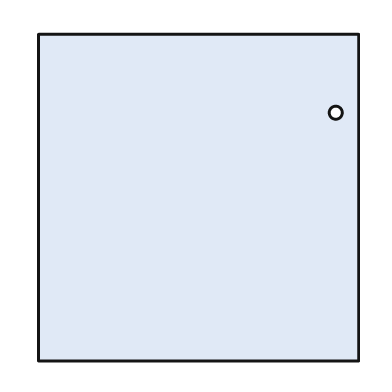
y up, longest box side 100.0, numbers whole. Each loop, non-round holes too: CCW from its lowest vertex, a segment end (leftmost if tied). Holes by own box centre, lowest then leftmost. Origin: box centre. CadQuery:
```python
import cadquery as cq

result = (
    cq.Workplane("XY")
    .moveTo(-49.0, -50.0)
    .lineTo(49.0, -50.0)
    .lineTo(49.0, 50.0)
    .lineTo(-49.0, 50.0)
    .close()
    .moveTo(42.0, 26.0)
    .circle(2.0)
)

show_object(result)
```